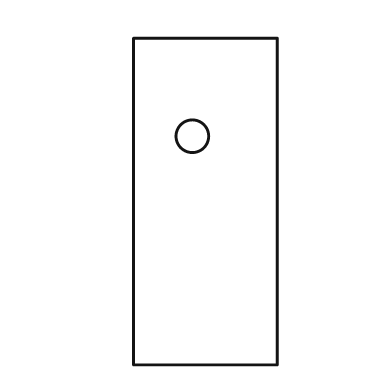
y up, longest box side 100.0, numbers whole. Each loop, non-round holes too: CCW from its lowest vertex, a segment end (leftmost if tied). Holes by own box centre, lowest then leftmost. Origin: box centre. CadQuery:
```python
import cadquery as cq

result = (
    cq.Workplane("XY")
    .moveTo(-22.0, -50.0)
    .lineTo(22.0, -50.0)
    .lineTo(22.0, 50.0)
    .lineTo(-22.0, 50.0)
    .close()
    .moveTo(-4.0, 20.0)
    .circle(5.0)
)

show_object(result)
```